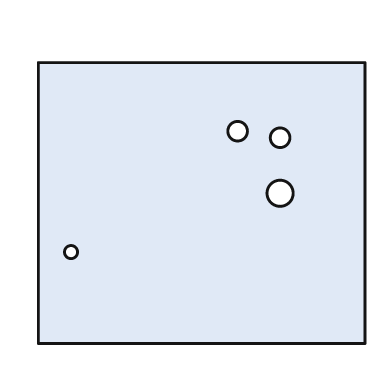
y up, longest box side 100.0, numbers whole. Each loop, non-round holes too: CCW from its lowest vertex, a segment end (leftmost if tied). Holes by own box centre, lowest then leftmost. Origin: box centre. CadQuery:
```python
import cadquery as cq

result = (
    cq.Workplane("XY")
    .moveTo(-50.0, -43.0)
    .lineTo(50.0, -43.0)
    .lineTo(50.0, 43.0)
    .lineTo(-50.0, 43.0)
    .close()
    .moveTo(-40.0, -15.0)
    .circle(2.0)
    .moveTo(24.0, 3.0)
    .circle(4.0)
    .moveTo(24.0, 20.0)
    .circle(3.0)
    .moveTo(11.0, 22.0)
    .circle(3.0)
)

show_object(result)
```